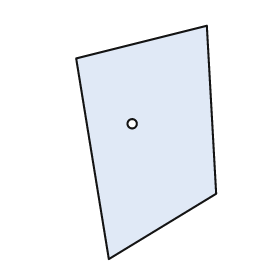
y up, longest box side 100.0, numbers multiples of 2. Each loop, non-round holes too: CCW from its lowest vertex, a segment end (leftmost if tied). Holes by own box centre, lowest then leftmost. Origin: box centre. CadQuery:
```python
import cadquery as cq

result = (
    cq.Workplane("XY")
    .moveTo(-16.0, -50.0)
    .lineTo(30.0, -22.0)
    .lineTo(26.0, 50.0)
    .lineTo(-30.0, 36.0)
    .close()
    .moveTo(-6.0, 8.0)
    .circle(2.0)
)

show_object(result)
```